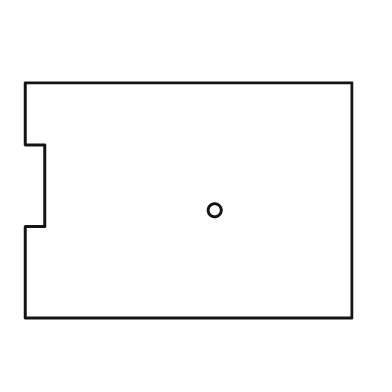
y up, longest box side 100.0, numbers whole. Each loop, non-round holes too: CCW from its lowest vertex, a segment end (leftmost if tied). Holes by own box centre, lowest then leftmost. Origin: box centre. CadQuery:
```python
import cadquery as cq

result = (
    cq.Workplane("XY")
    .moveTo(-50.0, -36.0)
    .lineTo(50.0, -36.0)
    .lineTo(50.0, 36.0)
    .lineTo(-50.0, 36.0)
    .lineTo(-50.0, 17.0)
    .lineTo(-44.0, 17.0)
    .lineTo(-44.0, -8.0)
    .lineTo(-50.0, -8.0)
    .close()
    .moveTo(8.0, -3.0)
    .circle(2.0)
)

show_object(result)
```